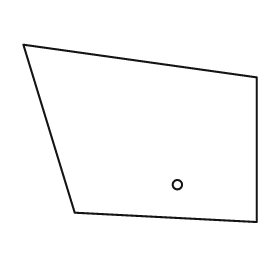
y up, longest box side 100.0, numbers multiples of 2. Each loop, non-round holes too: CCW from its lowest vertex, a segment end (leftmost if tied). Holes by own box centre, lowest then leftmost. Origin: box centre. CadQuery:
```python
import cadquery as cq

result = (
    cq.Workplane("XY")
    .moveTo(50.0, -38.0)
    .lineTo(50.0, 24.0)
    .lineTo(-50.0, 38.0)
    .lineTo(-28.0, -34.0)
    .close()
    .moveTo(16.0, -22.0)
    .circle(2.0)
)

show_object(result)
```